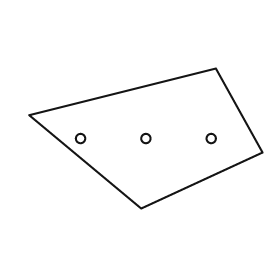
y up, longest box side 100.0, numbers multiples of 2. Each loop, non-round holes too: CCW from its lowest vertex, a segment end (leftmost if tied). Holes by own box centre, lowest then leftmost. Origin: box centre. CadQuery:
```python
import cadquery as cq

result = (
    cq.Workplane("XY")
    .moveTo(-2.0, -30.0)
    .lineTo(50.0, -6.0)
    .lineTo(30.0, 30.0)
    .lineTo(-50.0, 10.0)
    .close()
    .moveTo(-28.0, 0.0)
    .circle(2.0)
    .moveTo(0.0, 0.0)
    .circle(2.0)
    .moveTo(28.0, 0.0)
    .circle(2.0)
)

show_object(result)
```